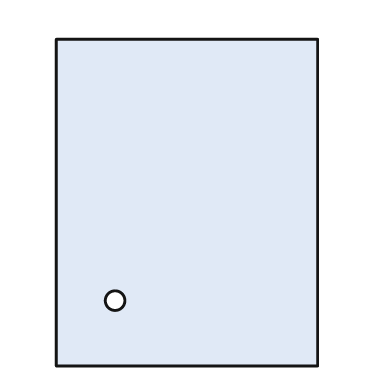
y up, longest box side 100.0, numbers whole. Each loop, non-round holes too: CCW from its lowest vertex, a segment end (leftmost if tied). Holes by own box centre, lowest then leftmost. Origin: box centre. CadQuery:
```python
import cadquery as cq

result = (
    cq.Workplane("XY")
    .moveTo(-40.0, -50.0)
    .lineTo(40.0, -50.0)
    .lineTo(40.0, 50.0)
    .lineTo(-40.0, 50.0)
    .close()
    .moveTo(-22.0, -30.0)
    .circle(3.0)
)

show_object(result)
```